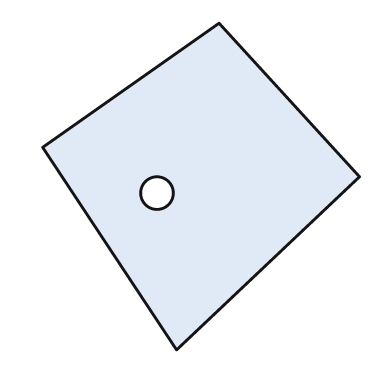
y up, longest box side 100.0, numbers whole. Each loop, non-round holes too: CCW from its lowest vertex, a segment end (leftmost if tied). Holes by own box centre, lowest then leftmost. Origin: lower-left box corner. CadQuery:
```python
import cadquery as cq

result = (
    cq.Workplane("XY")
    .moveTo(41.0, 0.0)
    .lineTo(97.0, 53.0)
    .lineTo(54.0, 100.0)
    .lineTo(0.0, 62.0)
    .close()
    .moveTo(35.0, 48.0)
    .circle(5.0)
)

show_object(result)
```